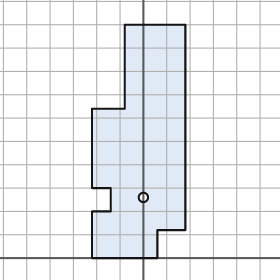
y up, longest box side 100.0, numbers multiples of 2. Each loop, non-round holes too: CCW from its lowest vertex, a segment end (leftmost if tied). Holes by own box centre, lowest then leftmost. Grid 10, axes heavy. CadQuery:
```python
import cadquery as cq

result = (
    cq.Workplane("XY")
    .moveTo(-22.0, 0.0)
    .lineTo(6.0, 0.0)
    .lineTo(6.0, 12.0)
    .lineTo(18.0, 12.0)
    .lineTo(18.0, 100.0)
    .lineTo(-8.0, 100.0)
    .lineTo(-8.0, 64.0)
    .lineTo(-22.0, 64.0)
    .lineTo(-22.0, 30.0)
    .lineTo(-14.0, 30.0)
    .lineTo(-14.0, 20.0)
    .lineTo(-22.0, 20.0)
    .close()
    .moveTo(0.0, 26.0)
    .circle(2.0)
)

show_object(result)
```